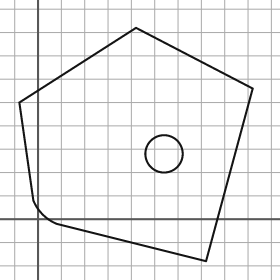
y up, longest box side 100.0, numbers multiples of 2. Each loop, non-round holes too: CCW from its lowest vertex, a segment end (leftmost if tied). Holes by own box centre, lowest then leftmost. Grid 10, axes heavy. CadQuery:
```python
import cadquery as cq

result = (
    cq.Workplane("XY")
    .moveTo(72.0, -18.0)
    .lineTo(92.0, 56.0)
    .lineTo(42.0, 82.0)
    .lineTo(-8.0, 50.0)
    .lineTo(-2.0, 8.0)
    .threePointArc((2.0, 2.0), (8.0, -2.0))
    .close()
    .moveTo(54.0, 28.0)
    .circle(8.0)
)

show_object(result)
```